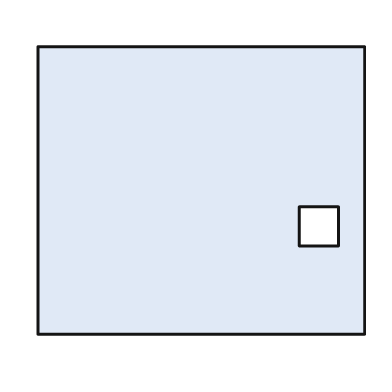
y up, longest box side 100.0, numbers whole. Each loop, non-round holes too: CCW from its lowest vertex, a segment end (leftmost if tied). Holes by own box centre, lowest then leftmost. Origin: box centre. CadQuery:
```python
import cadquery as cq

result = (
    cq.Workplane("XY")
    .moveTo(-50.0, -44.0)
    .lineTo(50.0, -44.0)
    .lineTo(50.0, 44.0)
    .lineTo(-50.0, 44.0)
    .close()
    .moveTo(30.0, -17.0)
    .lineTo(42.0, -17.0)
    .lineTo(42.0, -5.0)
    .lineTo(30.0, -5.0)
    .close()
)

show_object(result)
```